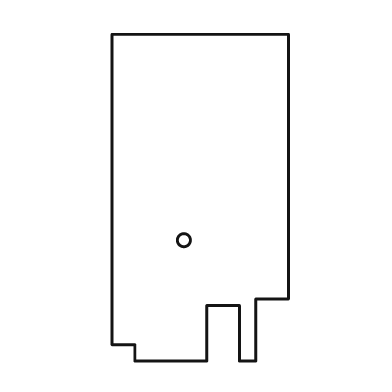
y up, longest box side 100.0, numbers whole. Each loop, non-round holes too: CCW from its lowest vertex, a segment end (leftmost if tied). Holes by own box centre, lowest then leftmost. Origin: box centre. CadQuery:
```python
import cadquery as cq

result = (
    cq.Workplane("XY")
    .moveTo(-20.0, -50.0)
    .lineTo(2.0, -50.0)
    .lineTo(2.0, -33.0)
    .lineTo(12.0, -33.0)
    .lineTo(12.0, -50.0)
    .lineTo(17.0, -50.0)
    .lineTo(17.0, -31.0)
    .lineTo(27.0, -31.0)
    .lineTo(27.0, 50.0)
    .lineTo(-27.0, 50.0)
    .lineTo(-27.0, -45.0)
    .lineTo(-20.0, -45.0)
    .close()
    .moveTo(-5.0, -13.0)
    .circle(2.0)
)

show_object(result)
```